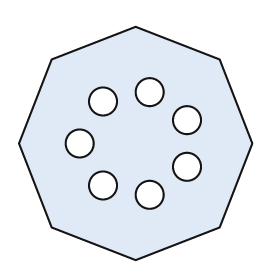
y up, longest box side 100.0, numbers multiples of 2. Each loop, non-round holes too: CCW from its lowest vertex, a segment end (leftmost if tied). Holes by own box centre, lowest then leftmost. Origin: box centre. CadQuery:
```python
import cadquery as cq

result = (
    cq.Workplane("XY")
    .moveTo(0.0, -50.0)
    .lineTo(36.0, -36.0)
    .lineTo(50.0, 0.0)
    .lineTo(36.0, 36.0)
    .lineTo(0.0, 50.0)
    .lineTo(-36.0, 36.0)
    .lineTo(-50.0, 0.0)
    .lineTo(-36.0, -36.0)
    .close()
    .moveTo(6.0, -22.0)
    .circle(6.0)
    .moveTo(-14.0, -18.0)
    .circle(6.0)
    .moveTo(22.0, -10.0)
    .circle(6.0)
    .moveTo(-24.0, 0.0)
    .circle(6.0)
    .moveTo(22.0, 10.0)
    .circle(6.0)
    .moveTo(-14.0, 18.0)
    .circle(6.0)
    .moveTo(6.0, 22.0)
    .circle(6.0)
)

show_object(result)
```